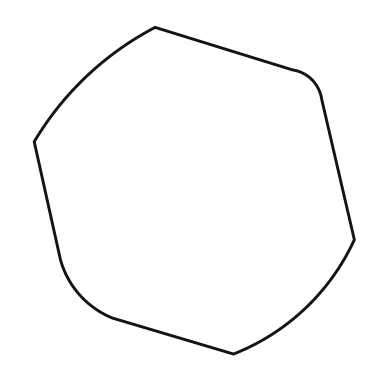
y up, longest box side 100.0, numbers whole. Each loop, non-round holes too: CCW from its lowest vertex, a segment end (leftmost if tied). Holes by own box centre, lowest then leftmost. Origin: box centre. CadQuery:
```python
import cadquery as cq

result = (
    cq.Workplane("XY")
    .moveTo(12.0, -50.0)
    .threePointArc((34.0, -36.0), (49.0, -15.0))
    .lineTo(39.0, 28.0)
    .threePointArc((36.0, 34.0), (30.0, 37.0))
    .lineTo(-12.0, 50.0)
    .threePointArc((-33.0, 35.0), (-49.0, 15.0))
    .lineTo(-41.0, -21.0)
    .threePointArc((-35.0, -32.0), (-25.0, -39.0))
    .close()
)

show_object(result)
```